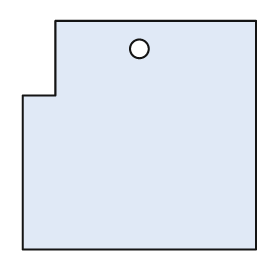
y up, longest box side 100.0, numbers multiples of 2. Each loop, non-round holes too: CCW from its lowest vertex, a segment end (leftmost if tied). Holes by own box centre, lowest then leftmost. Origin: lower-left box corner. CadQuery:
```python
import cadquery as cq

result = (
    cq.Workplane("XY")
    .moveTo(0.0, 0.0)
    .lineTo(100.0, 0.0)
    .lineTo(100.0, 98.0)
    .lineTo(14.0, 98.0)
    .lineTo(14.0, 66.0)
    .lineTo(0.0, 66.0)
    .close()
    .moveTo(50.0, 86.0)
    .circle(4.0)
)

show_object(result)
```